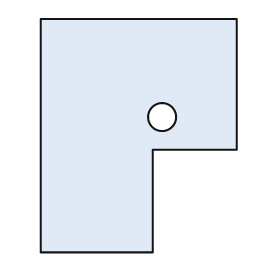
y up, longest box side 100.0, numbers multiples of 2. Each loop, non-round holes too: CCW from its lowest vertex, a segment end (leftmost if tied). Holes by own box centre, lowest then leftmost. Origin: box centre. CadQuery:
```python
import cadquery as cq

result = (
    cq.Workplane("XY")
    .moveTo(-42.0, -50.0)
    .lineTo(6.0, -50.0)
    .lineTo(6.0, -6.0)
    .lineTo(42.0, -6.0)
    .lineTo(42.0, 50.0)
    .lineTo(-42.0, 50.0)
    .close()
    .moveTo(10.0, 8.0)
    .circle(6.0)
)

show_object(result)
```